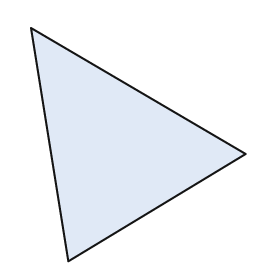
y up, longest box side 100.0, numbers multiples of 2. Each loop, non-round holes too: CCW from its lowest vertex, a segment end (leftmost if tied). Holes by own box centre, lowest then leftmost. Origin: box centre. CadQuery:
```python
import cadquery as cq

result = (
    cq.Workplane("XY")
    .moveTo(-30.0, -50.0)
    .lineTo(46.0, -4.0)
    .lineTo(-46.0, 50.0)
    .close()
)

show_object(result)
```